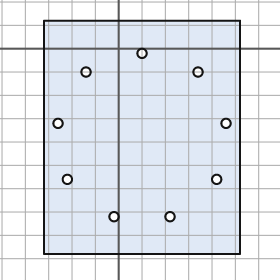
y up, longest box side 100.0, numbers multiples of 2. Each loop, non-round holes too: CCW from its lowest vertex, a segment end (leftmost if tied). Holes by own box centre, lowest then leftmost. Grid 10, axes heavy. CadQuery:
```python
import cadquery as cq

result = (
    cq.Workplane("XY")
    .moveTo(-32.0, -88.0)
    .lineTo(52.0, -88.0)
    .lineTo(52.0, 12.0)
    .lineTo(-32.0, 12.0)
    .close()
    .moveTo(-2.0, -72.0)
    .circle(2.0)
    .moveTo(22.0, -72.0)
    .circle(2.0)
    .moveTo(-22.0, -56.0)
    .circle(2.0)
    .moveTo(42.0, -56.0)
    .circle(2.0)
    .moveTo(-26.0, -32.0)
    .circle(2.0)
    .moveTo(46.0, -32.0)
    .circle(2.0)
    .moveTo(-14.0, -10.0)
    .circle(2.0)
    .moveTo(34.0, -10.0)
    .circle(2.0)
    .moveTo(10.0, -2.0)
    .circle(2.0)
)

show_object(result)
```